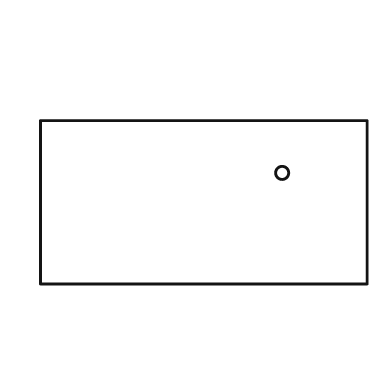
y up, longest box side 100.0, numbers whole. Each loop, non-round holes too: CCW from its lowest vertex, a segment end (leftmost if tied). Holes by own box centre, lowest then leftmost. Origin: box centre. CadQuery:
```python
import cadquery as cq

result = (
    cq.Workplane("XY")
    .moveTo(-50.0, -25.0)
    .lineTo(50.0, -25.0)
    .lineTo(50.0, 25.0)
    .lineTo(-50.0, 25.0)
    .close()
    .moveTo(24.0, 9.0)
    .circle(2.0)
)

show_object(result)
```